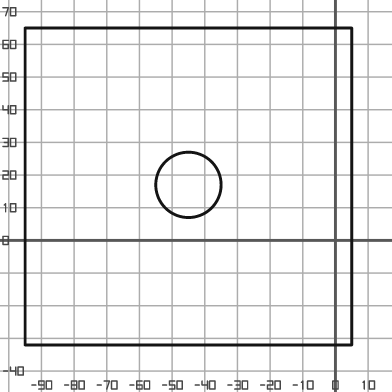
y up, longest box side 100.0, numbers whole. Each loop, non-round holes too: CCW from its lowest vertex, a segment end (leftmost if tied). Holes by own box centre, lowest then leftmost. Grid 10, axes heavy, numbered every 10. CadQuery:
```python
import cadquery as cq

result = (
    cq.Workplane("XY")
    .moveTo(-95.0, -32.0)
    .lineTo(5.0, -32.0)
    .lineTo(5.0, 65.0)
    .lineTo(-95.0, 65.0)
    .close()
    .moveTo(-45.0, 17.0)
    .circle(10.0)
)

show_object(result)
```